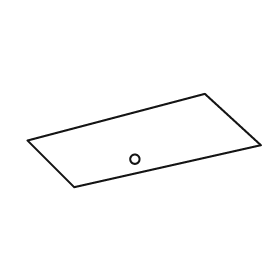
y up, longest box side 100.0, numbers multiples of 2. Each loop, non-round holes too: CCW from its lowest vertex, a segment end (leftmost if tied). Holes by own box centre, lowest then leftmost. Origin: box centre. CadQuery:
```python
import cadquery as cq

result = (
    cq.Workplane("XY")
    .moveTo(-30.0, -20.0)
    .lineTo(50.0, -2.0)
    .lineTo(26.0, 20.0)
    .lineTo(-50.0, 0.0)
    .close()
    .moveTo(-4.0, -8.0)
    .circle(2.0)
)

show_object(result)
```